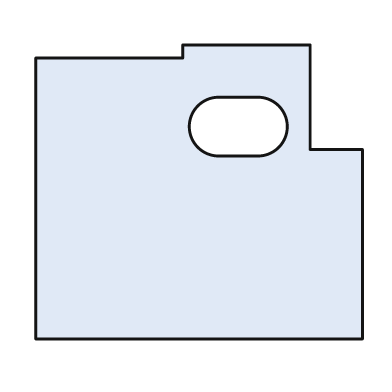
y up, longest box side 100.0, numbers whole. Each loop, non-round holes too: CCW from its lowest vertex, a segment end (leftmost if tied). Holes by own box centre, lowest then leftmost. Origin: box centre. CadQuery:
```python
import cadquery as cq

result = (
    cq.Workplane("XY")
    .moveTo(-50.0, -45.0)
    .lineTo(50.0, -45.0)
    .lineTo(50.0, 13.0)
    .lineTo(34.0, 13.0)
    .lineTo(34.0, 45.0)
    .lineTo(-5.0, 45.0)
    .lineTo(-5.0, 41.0)
    .lineTo(-50.0, 41.0)
    .close()
    .moveTo(6.0, 11.0)
    .lineTo(18.0, 11.0)
    .threePointArc((27.0, 20.0), (18.0, 29.0))
    .lineTo(6.0, 29.0)
    .threePointArc((-3.0, 20.0), (6.0, 11.0))
    .close()
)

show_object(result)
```